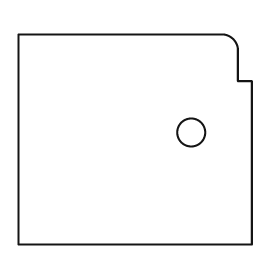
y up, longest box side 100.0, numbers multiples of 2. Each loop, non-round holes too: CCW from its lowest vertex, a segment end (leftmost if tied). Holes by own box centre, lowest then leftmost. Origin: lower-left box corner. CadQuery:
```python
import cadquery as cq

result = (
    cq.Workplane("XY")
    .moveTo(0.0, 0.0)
    .lineTo(100.0, 0.0)
    .lineTo(100.0, 70.0)
    .lineTo(94.0, 70.0)
    .lineTo(94.0, 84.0)
    .threePointArc((92.0, 88.0), (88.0, 90.0))
    .lineTo(0.0, 90.0)
    .close()
    .moveTo(74.0, 48.0)
    .circle(6.0)
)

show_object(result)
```